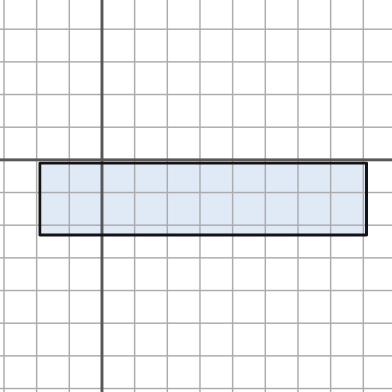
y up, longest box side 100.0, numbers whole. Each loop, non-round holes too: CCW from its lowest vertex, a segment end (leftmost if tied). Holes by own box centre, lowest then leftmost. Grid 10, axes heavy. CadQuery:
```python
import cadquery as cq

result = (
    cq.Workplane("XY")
    .moveTo(-19.0, -23.0)
    .lineTo(81.0, -23.0)
    .lineTo(81.0, -1.0)
    .lineTo(-19.0, -1.0)
    .close()
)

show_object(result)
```